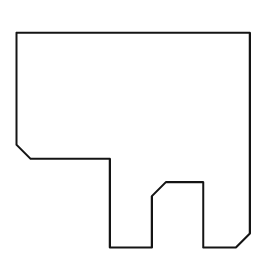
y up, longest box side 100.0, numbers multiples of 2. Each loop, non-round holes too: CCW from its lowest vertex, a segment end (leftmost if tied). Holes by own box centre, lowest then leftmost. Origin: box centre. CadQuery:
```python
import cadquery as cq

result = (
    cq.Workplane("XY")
    .moveTo(-10.0, -46.0)
    .lineTo(8.0, -46.0)
    .lineTo(8.0, -24.0)
    .lineTo(14.0, -18.0)
    .lineTo(30.0, -18.0)
    .lineTo(30.0, -46.0)
    .lineTo(44.0, -46.0)
    .lineTo(50.0, -40.0)
    .lineTo(50.0, 46.0)
    .lineTo(-50.0, 46.0)
    .lineTo(-50.0, -2.0)
    .lineTo(-44.0, -8.0)
    .lineTo(-10.0, -8.0)
    .close()
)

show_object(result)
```